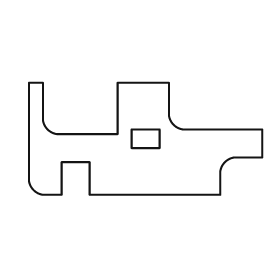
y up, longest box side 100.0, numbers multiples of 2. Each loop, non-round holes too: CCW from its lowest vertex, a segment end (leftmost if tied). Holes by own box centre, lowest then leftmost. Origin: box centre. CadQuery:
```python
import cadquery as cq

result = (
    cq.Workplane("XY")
    .moveTo(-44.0, -24.0)
    .lineTo(-36.0, -24.0)
    .lineTo(-36.0, -10.0)
    .lineTo(-24.0, -10.0)
    .lineTo(-24.0, -24.0)
    .lineTo(32.0, -24.0)
    .lineTo(32.0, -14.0)
    .threePointArc((34.0, -10.0), (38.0, -8.0))
    .lineTo(50.0, -8.0)
    .lineTo(50.0, 4.0)
    .lineTo(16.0, 4.0)
    .threePointArc((12.0, 6.0), (10.0, 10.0))
    .lineTo(10.0, 24.0)
    .lineTo(-12.0, 24.0)
    .lineTo(-12.0, 2.0)
    .lineTo(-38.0, 2.0)
    .threePointArc((-42.0, 4.0), (-44.0, 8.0))
    .lineTo(-44.0, 24.0)
    .lineTo(-50.0, 24.0)
    .lineTo(-50.0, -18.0)
    .threePointArc((-48.0, -22.0), (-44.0, -24.0))
    .close()
    .moveTo(-6.0, -4.0)
    .lineTo(6.0, -4.0)
    .lineTo(6.0, 4.0)
    .lineTo(-6.0, 4.0)
    .close()
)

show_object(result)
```